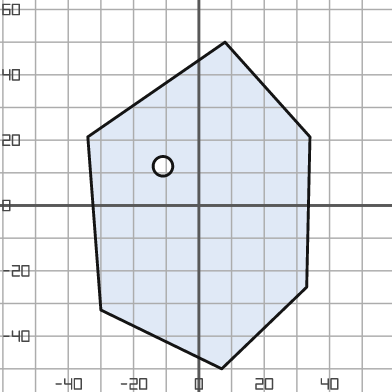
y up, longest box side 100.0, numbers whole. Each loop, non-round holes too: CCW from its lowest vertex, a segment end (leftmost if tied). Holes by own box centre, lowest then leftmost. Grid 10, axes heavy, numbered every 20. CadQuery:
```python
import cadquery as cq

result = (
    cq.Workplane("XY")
    .moveTo(7.0, -50.0)
    .lineTo(33.0, -25.0)
    .lineTo(34.0, 21.0)
    .lineTo(8.0, 50.0)
    .lineTo(-34.0, 21.0)
    .lineTo(-30.0, -32.0)
    .close()
    .moveTo(-11.0, 12.0)
    .circle(3.0)
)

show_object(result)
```